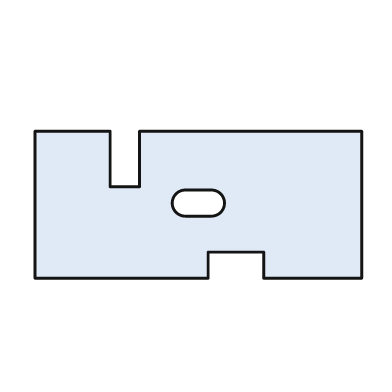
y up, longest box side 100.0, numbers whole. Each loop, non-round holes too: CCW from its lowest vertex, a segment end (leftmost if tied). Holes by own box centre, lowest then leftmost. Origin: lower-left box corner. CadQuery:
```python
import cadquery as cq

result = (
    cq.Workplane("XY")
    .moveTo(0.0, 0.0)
    .lineTo(53.0, 0.0)
    .lineTo(53.0, 8.0)
    .lineTo(70.0, 8.0)
    .lineTo(70.0, 0.0)
    .lineTo(100.0, 0.0)
    .lineTo(100.0, 45.0)
    .lineTo(32.0, 45.0)
    .lineTo(32.0, 28.0)
    .lineTo(23.0, 28.0)
    .lineTo(23.0, 45.0)
    .lineTo(0.0, 45.0)
    .close()
    .moveTo(46.0, 19.0)
    .lineTo(54.0, 19.0)
    .threePointArc((58.0, 23.0), (54.0, 27.0))
    .lineTo(46.0, 27.0)
    .threePointArc((42.0, 23.0), (46.0, 19.0))
    .close()
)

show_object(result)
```